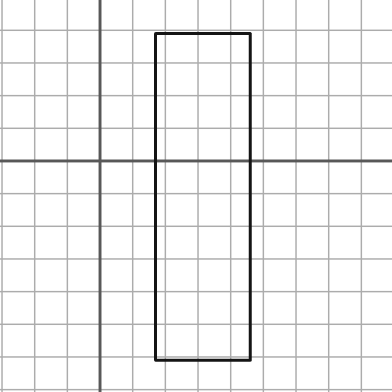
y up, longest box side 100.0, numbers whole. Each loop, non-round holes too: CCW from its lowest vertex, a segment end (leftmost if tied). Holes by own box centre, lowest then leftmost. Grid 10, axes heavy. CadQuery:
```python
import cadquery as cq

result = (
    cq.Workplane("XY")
    .moveTo(17.0, -61.0)
    .lineTo(46.0, -61.0)
    .lineTo(46.0, 39.0)
    .lineTo(17.0, 39.0)
    .close()
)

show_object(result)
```